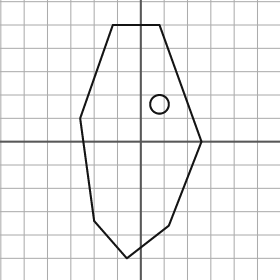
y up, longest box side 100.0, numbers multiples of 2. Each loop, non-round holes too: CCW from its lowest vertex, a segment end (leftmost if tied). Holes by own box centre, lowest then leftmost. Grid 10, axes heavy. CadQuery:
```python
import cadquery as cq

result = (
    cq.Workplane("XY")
    .moveTo(-6.0, -50.0)
    .lineTo(12.0, -36.0)
    .lineTo(26.0, 0.0)
    .lineTo(8.0, 50.0)
    .lineTo(-12.0, 50.0)
    .lineTo(-26.0, 10.0)
    .lineTo(-20.0, -34.0)
    .close()
    .moveTo(8.0, 16.0)
    .circle(4.0)
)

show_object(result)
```